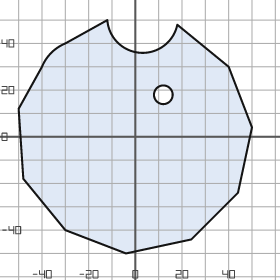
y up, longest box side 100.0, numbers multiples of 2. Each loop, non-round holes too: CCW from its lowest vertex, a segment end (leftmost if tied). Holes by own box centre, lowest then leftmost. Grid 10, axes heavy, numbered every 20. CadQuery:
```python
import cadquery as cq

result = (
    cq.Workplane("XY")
    .moveTo(-4.0, -50.0)
    .lineTo(24.0, -44.0)
    .lineTo(44.0, -24.0)
    .lineTo(50.0, 4.0)
    .lineTo(40.0, 30.0)
    .lineTo(18.0, 48.0)
    .threePointArc((2.0, 36.0), (-12.0, 50.0))
    .lineTo(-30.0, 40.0)
    .threePointArc((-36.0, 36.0), (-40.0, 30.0))
    .lineTo(-50.0, 12.0)
    .lineTo(-48.0, -18.0)
    .lineTo(-30.0, -40.0)
    .close()
    .moveTo(12.0, 18.0)
    .circle(4.0)
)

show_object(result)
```